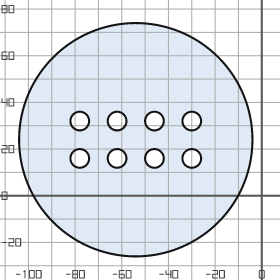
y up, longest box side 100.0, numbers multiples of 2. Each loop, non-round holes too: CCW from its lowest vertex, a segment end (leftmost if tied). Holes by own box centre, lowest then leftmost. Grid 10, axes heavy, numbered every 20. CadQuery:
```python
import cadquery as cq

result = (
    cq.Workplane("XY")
    .moveTo(-54.0, 24.0)
    .circle(50.0)
    .moveTo(-78.0, 16.0)
    .circle(4.0)
    .moveTo(-62.0, 16.0)
    .circle(4.0)
    .moveTo(-46.0, 16.0)
    .circle(4.0)
    .moveTo(-30.0, 16.0)
    .circle(4.0)
    .moveTo(-78.0, 32.0)
    .circle(4.0)
    .moveTo(-62.0, 32.0)
    .circle(4.0)
    .moveTo(-46.0, 32.0)
    .circle(4.0)
    .moveTo(-30.0, 32.0)
    .circle(4.0)
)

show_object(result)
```